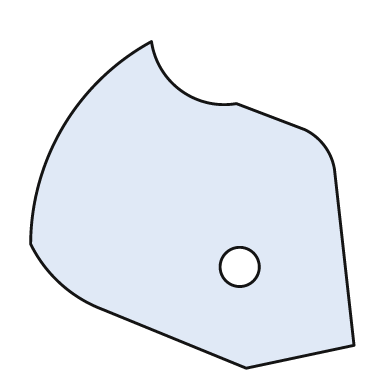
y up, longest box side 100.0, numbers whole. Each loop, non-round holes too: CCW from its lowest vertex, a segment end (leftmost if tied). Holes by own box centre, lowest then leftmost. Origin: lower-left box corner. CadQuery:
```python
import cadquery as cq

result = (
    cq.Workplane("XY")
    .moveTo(66.0, 0.0)
    .lineTo(99.0, 7.0)
    .lineTo(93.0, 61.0)
    .threePointArc((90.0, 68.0), (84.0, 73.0))
    .lineTo(63.0, 81.0)
    .threePointArc((46.0, 85.0), (37.0, 100.0))
    .threePointArc((10.0, 74.0), (0.0, 38.0))
    .threePointArc((9.0, 26.0), (22.0, 18.0))
    .close()
    .moveTo(64.0, 31.0)
    .circle(6.0)
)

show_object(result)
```